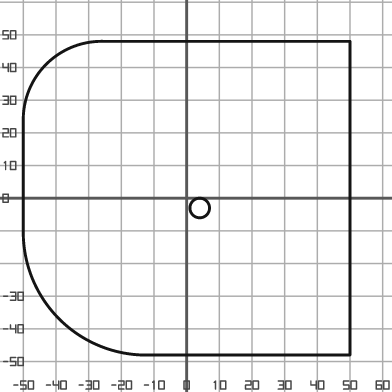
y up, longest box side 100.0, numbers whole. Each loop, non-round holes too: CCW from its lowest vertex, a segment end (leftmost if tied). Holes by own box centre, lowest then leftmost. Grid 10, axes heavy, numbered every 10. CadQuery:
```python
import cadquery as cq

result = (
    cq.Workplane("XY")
    .moveTo(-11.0, -48.0)
    .lineTo(50.0, -48.0)
    .lineTo(50.0, 48.0)
    .lineTo(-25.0, 48.0)
    .threePointArc((-43.0, 41.0), (-50.0, 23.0))
    .lineTo(-50.0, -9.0)
    .threePointArc((-39.0, -37.0), (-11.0, -48.0))
    .close()
    .moveTo(4.0, -3.0)
    .circle(3.0)
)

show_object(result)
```